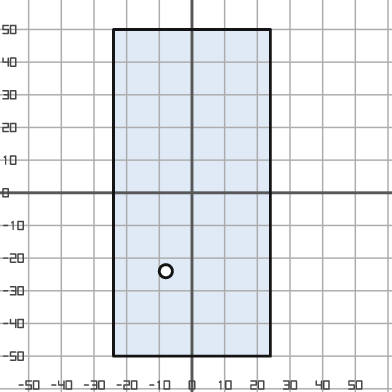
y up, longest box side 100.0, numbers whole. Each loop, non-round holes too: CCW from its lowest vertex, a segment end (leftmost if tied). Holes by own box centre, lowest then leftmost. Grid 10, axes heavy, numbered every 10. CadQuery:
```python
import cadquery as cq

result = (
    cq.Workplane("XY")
    .moveTo(-24.0, -50.0)
    .lineTo(24.0, -50.0)
    .lineTo(24.0, 50.0)
    .lineTo(-24.0, 50.0)
    .close()
    .moveTo(-8.0, -24.0)
    .circle(2.0)
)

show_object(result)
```